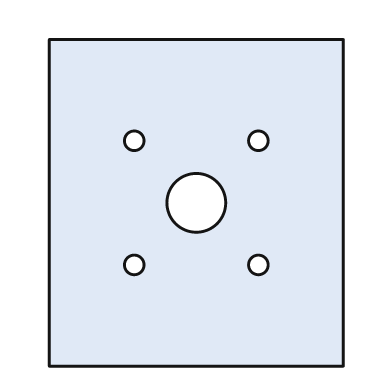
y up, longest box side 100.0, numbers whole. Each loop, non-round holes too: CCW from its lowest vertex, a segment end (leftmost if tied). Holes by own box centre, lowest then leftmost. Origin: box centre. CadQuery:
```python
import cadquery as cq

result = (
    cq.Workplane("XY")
    .moveTo(-45.0, -50.0)
    .lineTo(45.0, -50.0)
    .lineTo(45.0, 50.0)
    .lineTo(-45.0, 50.0)
    .close()
    .moveTo(-19.0, -19.0)
    .circle(3.0)
    .moveTo(19.0, -19.0)
    .circle(3.0)
    .moveTo(0.0, 0.0)
    .circle(9.0)
    .moveTo(-19.0, 19.0)
    .circle(3.0)
    .moveTo(19.0, 19.0)
    .circle(3.0)
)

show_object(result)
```